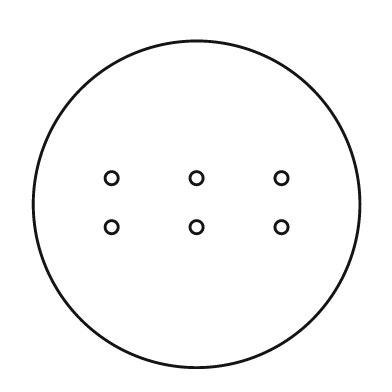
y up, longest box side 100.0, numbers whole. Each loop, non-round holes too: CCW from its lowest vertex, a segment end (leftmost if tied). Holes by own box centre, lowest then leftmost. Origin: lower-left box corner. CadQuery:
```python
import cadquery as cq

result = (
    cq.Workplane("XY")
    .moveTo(50.0, 50.0)
    .circle(50.0)
    .moveTo(24.0, 43.0)
    .circle(2.0)
    .moveTo(50.0, 43.0)
    .circle(2.0)
    .moveTo(76.0, 43.0)
    .circle(2.0)
    .moveTo(24.0, 58.0)
    .circle(2.0)
    .moveTo(50.0, 58.0)
    .circle(2.0)
    .moveTo(76.0, 58.0)
    .circle(2.0)
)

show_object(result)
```